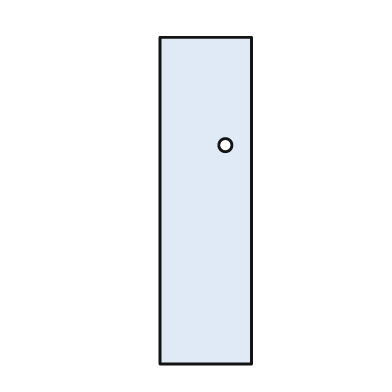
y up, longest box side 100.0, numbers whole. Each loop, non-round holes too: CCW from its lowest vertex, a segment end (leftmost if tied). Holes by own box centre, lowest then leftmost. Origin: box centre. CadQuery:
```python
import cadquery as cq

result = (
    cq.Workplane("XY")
    .moveTo(-14.0, -50.0)
    .lineTo(14.0, -50.0)
    .lineTo(14.0, 50.0)
    .lineTo(-14.0, 50.0)
    .close()
    .moveTo(6.0, 17.0)
    .circle(2.0)
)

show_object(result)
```